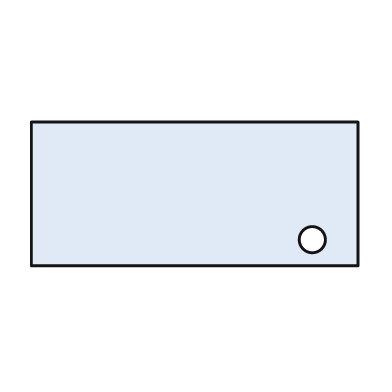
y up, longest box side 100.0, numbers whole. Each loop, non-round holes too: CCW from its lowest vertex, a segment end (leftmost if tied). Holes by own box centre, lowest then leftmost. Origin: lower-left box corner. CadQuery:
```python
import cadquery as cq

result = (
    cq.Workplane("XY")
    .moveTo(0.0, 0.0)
    .lineTo(100.0, 0.0)
    .lineTo(100.0, 44.0)
    .lineTo(0.0, 44.0)
    .close()
    .moveTo(86.0, 8.0)
    .circle(4.0)
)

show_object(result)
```